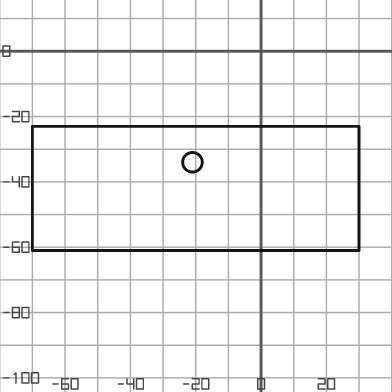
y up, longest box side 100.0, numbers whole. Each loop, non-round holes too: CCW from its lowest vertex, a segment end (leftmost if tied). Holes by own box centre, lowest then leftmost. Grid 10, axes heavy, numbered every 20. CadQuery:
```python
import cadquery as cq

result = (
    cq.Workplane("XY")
    .moveTo(-70.0, -61.0)
    .lineTo(30.0, -61.0)
    .lineTo(30.0, -23.0)
    .lineTo(-70.0, -23.0)
    .close()
    .moveTo(-21.0, -34.0)
    .circle(3.0)
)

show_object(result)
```